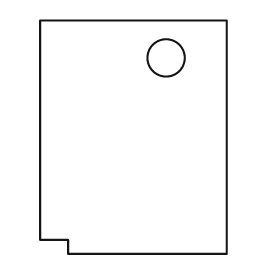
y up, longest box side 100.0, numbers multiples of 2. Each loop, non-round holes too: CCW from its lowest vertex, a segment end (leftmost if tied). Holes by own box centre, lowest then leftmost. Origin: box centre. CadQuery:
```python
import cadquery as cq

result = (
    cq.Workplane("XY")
    .moveTo(-28.0, -50.0)
    .lineTo(40.0, -50.0)
    .lineTo(40.0, 50.0)
    .lineTo(-40.0, 50.0)
    .lineTo(-40.0, -44.0)
    .lineTo(-28.0, -44.0)
    .close()
    .moveTo(14.0, 34.0)
    .circle(8.0)
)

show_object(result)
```